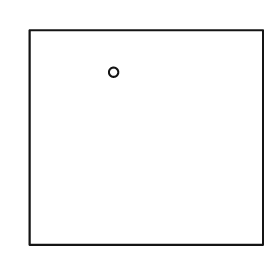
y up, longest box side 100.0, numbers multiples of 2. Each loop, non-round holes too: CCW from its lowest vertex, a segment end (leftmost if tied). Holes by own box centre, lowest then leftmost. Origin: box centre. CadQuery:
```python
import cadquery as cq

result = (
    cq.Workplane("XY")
    .moveTo(-50.0, -46.0)
    .lineTo(50.0, -46.0)
    .lineTo(50.0, 46.0)
    .lineTo(-50.0, 46.0)
    .close()
    .moveTo(-14.0, 28.0)
    .circle(2.0)
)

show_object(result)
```